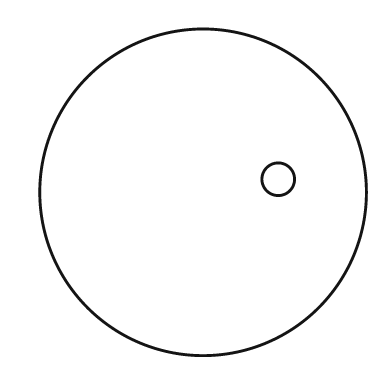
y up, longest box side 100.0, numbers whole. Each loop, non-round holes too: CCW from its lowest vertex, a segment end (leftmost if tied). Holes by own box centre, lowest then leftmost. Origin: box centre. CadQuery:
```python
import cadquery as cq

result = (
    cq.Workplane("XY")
    .moveTo(0.0, 0.0)
    .circle(50.0)
    .moveTo(23.0, 4.0)
    .circle(5.0)
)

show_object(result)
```